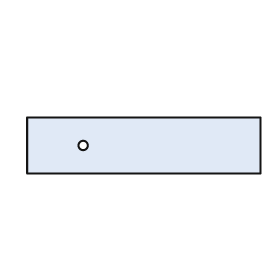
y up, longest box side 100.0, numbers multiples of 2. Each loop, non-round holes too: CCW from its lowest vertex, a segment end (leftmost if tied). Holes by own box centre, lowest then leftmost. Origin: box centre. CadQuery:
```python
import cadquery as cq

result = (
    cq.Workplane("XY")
    .moveTo(-50.0, -12.0)
    .lineTo(50.0, -12.0)
    .lineTo(50.0, 12.0)
    .lineTo(-50.0, 12.0)
    .close()
    .moveTo(-26.0, 0.0)
    .circle(2.0)
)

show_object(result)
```